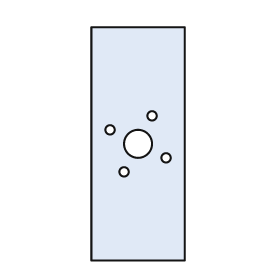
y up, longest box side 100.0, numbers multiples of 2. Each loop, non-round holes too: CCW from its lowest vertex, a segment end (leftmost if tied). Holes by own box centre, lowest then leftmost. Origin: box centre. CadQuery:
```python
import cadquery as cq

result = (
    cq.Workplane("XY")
    .moveTo(-20.0, -50.0)
    .lineTo(20.0, -50.0)
    .lineTo(20.0, 50.0)
    .lineTo(-20.0, 50.0)
    .close()
    .moveTo(-6.0, -12.0)
    .circle(2.0)
    .moveTo(12.0, -6.0)
    .circle(2.0)
    .moveTo(0.0, 0.0)
    .circle(6.0)
    .moveTo(-12.0, 6.0)
    .circle(2.0)
    .moveTo(6.0, 12.0)
    .circle(2.0)
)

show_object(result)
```